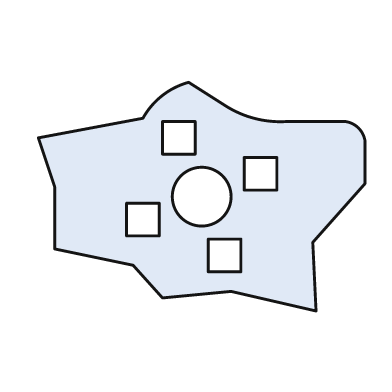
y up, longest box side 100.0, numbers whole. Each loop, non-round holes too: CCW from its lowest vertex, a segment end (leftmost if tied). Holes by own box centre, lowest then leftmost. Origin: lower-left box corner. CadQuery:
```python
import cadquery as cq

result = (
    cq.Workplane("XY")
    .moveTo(85.0, 0.0)
    .lineTo(84.0, 21.0)
    .lineTo(100.0, 39.0)
    .lineTo(100.0, 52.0)
    .threePointArc((98.0, 56.0), (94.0, 58.0))
    .lineTo(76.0, 58.0)
    .threePointArc((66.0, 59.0), (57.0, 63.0))
    .lineTo(46.0, 70.0)
    .threePointArc((38.0, 66.0), (32.0, 59.0))
    .lineTo(0.0, 53.0)
    .lineTo(5.0, 38.0)
    .lineTo(5.0, 19.0)
    .lineTo(29.0, 14.0)
    .lineTo(38.0, 4.0)
    .lineTo(59.0, 6.0)
    .close()
    .moveTo(52.0, 12.0)
    .lineTo(62.0, 12.0)
    .lineTo(62.0, 22.0)
    .lineTo(52.0, 22.0)
    .close()
    .moveTo(27.0, 23.0)
    .lineTo(37.0, 23.0)
    .lineTo(37.0, 33.0)
    .lineTo(27.0, 33.0)
    .close()
    .moveTo(50.0, 35.0)
    .circle(9.0)
    .moveTo(63.0, 37.0)
    .lineTo(73.0, 37.0)
    .lineTo(73.0, 47.0)
    .lineTo(63.0, 47.0)
    .close()
    .moveTo(38.0, 48.0)
    .lineTo(48.0, 48.0)
    .lineTo(48.0, 58.0)
    .lineTo(38.0, 58.0)
    .close()
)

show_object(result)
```